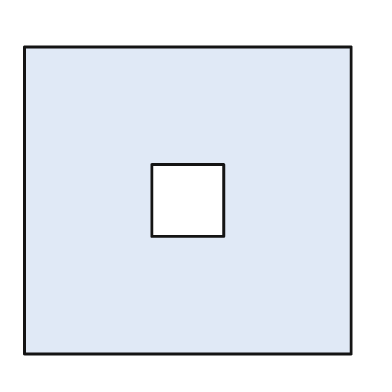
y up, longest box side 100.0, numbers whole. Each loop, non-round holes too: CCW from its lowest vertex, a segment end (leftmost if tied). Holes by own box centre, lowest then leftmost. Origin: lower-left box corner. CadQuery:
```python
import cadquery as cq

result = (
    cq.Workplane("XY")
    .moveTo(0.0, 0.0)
    .lineTo(100.0, 0.0)
    .lineTo(100.0, 94.0)
    .lineTo(0.0, 94.0)
    .close()
    .moveTo(39.0, 36.0)
    .lineTo(61.0, 36.0)
    .lineTo(61.0, 58.0)
    .lineTo(39.0, 58.0)
    .close()
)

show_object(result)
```